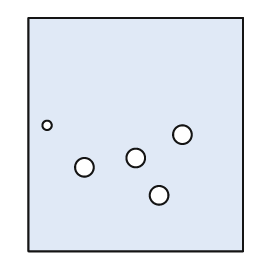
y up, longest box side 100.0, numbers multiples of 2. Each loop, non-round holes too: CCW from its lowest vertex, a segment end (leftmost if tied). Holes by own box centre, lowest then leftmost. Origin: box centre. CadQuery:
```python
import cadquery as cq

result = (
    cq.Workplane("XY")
    .moveTo(-46.0, -50.0)
    .lineTo(46.0, -50.0)
    .lineTo(46.0, 50.0)
    .lineTo(-46.0, 50.0)
    .close()
    .moveTo(10.0, -26.0)
    .circle(4.0)
    .moveTo(-22.0, -14.0)
    .circle(4.0)
    .moveTo(0.0, -10.0)
    .circle(4.0)
    .moveTo(20.0, 0.0)
    .circle(4.0)
    .moveTo(-38.0, 4.0)
    .circle(2.0)
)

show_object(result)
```